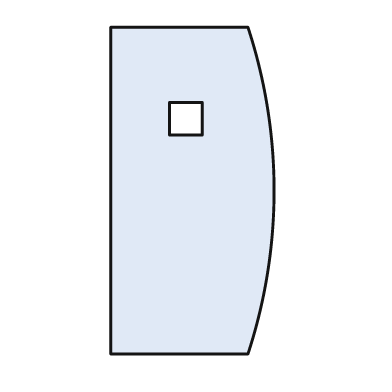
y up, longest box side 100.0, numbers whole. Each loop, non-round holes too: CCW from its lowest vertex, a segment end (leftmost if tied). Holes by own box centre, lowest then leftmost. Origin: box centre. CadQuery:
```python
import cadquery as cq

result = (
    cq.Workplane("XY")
    .moveTo(-25.0, -50.0)
    .lineTo(17.0, -50.0)
    .threePointArc((25.0, 0.0), (17.0, 50.0))
    .lineTo(-25.0, 50.0)
    .close()
    .moveTo(-7.0, 17.0)
    .lineTo(3.0, 17.0)
    .lineTo(3.0, 27.0)
    .lineTo(-7.0, 27.0)
    .close()
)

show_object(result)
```